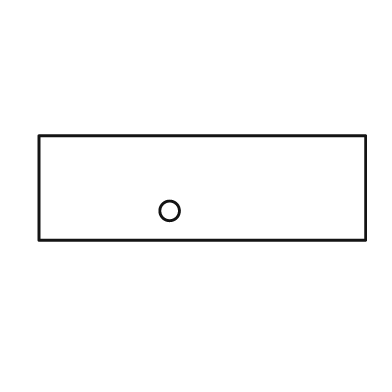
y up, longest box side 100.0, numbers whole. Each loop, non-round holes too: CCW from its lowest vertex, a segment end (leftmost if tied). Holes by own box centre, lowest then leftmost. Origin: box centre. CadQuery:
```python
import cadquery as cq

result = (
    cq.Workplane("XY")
    .moveTo(-50.0, -16.0)
    .lineTo(50.0, -16.0)
    .lineTo(50.0, 16.0)
    .lineTo(-50.0, 16.0)
    .close()
    .moveTo(-10.0, -7.0)
    .circle(3.0)
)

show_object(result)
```